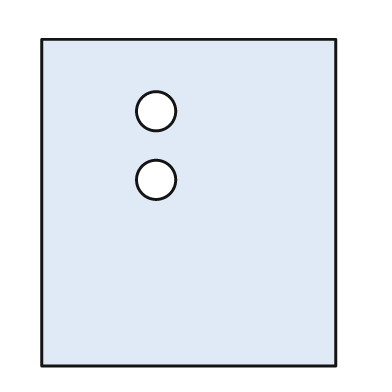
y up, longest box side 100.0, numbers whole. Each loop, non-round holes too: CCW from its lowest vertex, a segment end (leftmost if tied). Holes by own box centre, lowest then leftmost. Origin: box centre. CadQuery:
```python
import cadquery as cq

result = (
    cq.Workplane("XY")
    .moveTo(-45.0, -50.0)
    .lineTo(45.0, -50.0)
    .lineTo(45.0, 50.0)
    .lineTo(-45.0, 50.0)
    .close()
    .moveTo(-10.0, 7.0)
    .circle(6.0)
    .moveTo(-10.0, 28.0)
    .circle(6.0)
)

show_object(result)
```